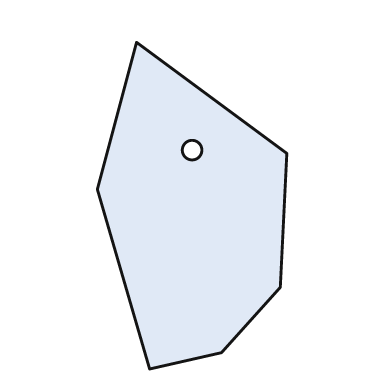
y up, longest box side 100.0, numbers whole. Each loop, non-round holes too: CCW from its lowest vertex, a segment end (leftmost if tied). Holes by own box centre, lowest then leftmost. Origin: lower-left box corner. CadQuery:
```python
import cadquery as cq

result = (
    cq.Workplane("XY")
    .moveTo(16.0, 0.0)
    .lineTo(38.0, 5.0)
    .lineTo(56.0, 25.0)
    .lineTo(58.0, 66.0)
    .lineTo(12.0, 100.0)
    .lineTo(0.0, 55.0)
    .close()
    .moveTo(29.0, 67.0)
    .circle(3.0)
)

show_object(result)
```